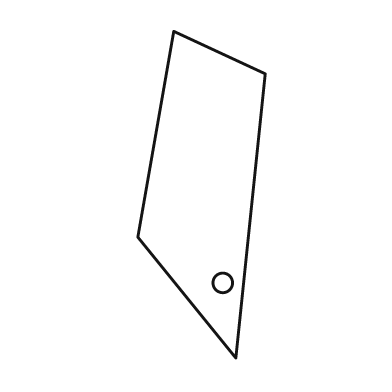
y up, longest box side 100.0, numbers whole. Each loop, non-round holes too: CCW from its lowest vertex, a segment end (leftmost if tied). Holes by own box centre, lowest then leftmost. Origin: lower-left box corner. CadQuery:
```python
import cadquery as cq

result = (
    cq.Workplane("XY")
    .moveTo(30.0, 0.0)
    .lineTo(39.0, 87.0)
    .lineTo(11.0, 100.0)
    .lineTo(0.0, 37.0)
    .close()
    .moveTo(26.0, 23.0)
    .circle(3.0)
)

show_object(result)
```